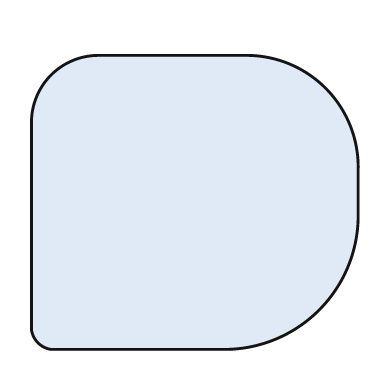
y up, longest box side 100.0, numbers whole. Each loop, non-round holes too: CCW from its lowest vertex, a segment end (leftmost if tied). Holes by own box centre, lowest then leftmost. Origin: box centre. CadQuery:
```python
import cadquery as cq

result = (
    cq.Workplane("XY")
    .moveTo(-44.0, -45.0)
    .lineTo(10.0, -45.0)
    .threePointArc((38.0, -33.0), (50.0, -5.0))
    .lineTo(50.0, 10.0)
    .threePointArc((40.0, 35.0), (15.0, 45.0))
    .lineTo(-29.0, 45.0)
    .threePointArc((-44.0, 39.0), (-50.0, 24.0))
    .lineTo(-50.0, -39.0)
    .threePointArc((-48.0, -43.0), (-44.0, -45.0))
    .close()
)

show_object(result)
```